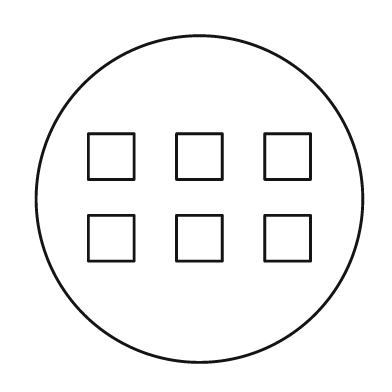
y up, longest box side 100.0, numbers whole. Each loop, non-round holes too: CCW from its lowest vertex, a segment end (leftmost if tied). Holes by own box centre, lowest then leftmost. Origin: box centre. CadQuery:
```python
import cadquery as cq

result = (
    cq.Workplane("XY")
    .moveTo(0.0, 0.0)
    .circle(50.0)
    .moveTo(-34.0, -19.0)
    .lineTo(-20.0, -19.0)
    .lineTo(-20.0, -5.0)
    .lineTo(-34.0, -5.0)
    .close()
    .moveTo(-7.0, -19.0)
    .lineTo(7.0, -19.0)
    .lineTo(7.0, -5.0)
    .lineTo(-7.0, -5.0)
    .close()
    .moveTo(20.0, -19.0)
    .lineTo(34.0, -19.0)
    .lineTo(34.0, -5.0)
    .lineTo(20.0, -5.0)
    .close()
    .moveTo(-34.0, 6.0)
    .lineTo(-20.0, 6.0)
    .lineTo(-20.0, 20.0)
    .lineTo(-34.0, 20.0)
    .close()
    .moveTo(-7.0, 6.0)
    .lineTo(7.0, 6.0)
    .lineTo(7.0, 20.0)
    .lineTo(-7.0, 20.0)
    .close()
    .moveTo(20.0, 6.0)
    .lineTo(34.0, 6.0)
    .lineTo(34.0, 20.0)
    .lineTo(20.0, 20.0)
    .close()
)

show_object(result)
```